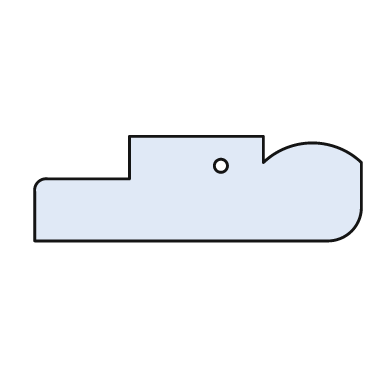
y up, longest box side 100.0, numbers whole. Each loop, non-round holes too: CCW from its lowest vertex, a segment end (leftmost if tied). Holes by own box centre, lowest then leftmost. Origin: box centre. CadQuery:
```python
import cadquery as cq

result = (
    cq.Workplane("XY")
    .moveTo(-50.0, -16.0)
    .lineTo(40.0, -16.0)
    .threePointArc((47.0, -13.0), (50.0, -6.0))
    .lineTo(50.0, 8.0)
    .threePointArc((35.0, 14.0), (20.0, 8.0))
    .lineTo(20.0, 16.0)
    .lineTo(-21.0, 16.0)
    .lineTo(-21.0, 3.0)
    .lineTo(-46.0, 3.0)
    .threePointArc((-49.0, 2.0), (-50.0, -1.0))
    .close()
    .moveTo(7.0, 7.0)
    .circle(2.0)
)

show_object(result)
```